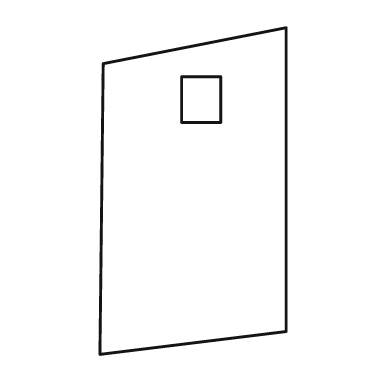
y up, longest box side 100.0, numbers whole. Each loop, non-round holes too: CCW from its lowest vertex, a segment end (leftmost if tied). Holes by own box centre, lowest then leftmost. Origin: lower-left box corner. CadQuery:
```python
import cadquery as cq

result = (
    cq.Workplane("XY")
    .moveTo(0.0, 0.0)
    .lineTo(57.0, 7.0)
    .lineTo(57.0, 100.0)
    .lineTo(1.0, 89.0)
    .close()
    .moveTo(25.0, 71.0)
    .lineTo(37.0, 71.0)
    .lineTo(37.0, 85.0)
    .lineTo(25.0, 85.0)
    .close()
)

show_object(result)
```